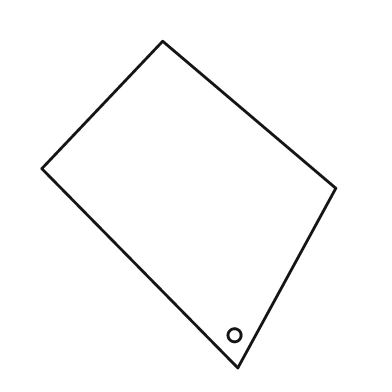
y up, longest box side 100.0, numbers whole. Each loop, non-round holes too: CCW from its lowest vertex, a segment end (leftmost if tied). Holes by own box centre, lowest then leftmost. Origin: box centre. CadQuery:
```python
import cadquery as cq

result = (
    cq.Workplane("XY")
    .moveTo(15.0, -50.0)
    .lineTo(45.0, 5.0)
    .lineTo(-8.0, 50.0)
    .lineTo(-45.0, 11.0)
    .close()
    .moveTo(14.0, -40.0)
    .circle(2.0)
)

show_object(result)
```